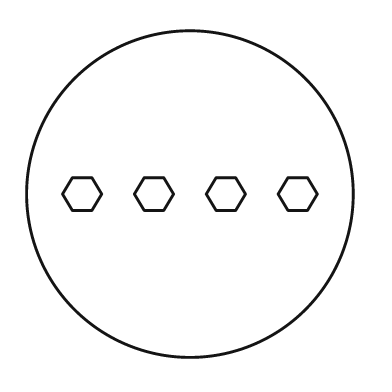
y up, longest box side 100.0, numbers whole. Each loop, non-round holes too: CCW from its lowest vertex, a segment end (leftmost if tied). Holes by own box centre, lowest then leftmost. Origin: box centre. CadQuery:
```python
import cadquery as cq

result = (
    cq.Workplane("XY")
    .moveTo(0.0, 0.0)
    .circle(50.0)
    .moveTo(-36.0, -5.0)
    .lineTo(-30.0, -5.0)
    .lineTo(-27.0, 0.0)
    .lineTo(-30.0, 5.0)
    .lineTo(-36.0, 5.0)
    .lineTo(-39.0, 0.0)
    .close()
    .moveTo(-14.0, -5.0)
    .lineTo(-8.0, -5.0)
    .lineTo(-5.0, 0.0)
    .lineTo(-8.0, 5.0)
    .lineTo(-14.0, 5.0)
    .lineTo(-17.0, 0.0)
    .close()
    .moveTo(8.0, -5.0)
    .lineTo(14.0, -5.0)
    .lineTo(17.0, 0.0)
    .lineTo(14.0, 5.0)
    .lineTo(8.0, 5.0)
    .lineTo(5.0, 0.0)
    .close()
    .moveTo(30.0, -5.0)
    .lineTo(36.0, -5.0)
    .lineTo(39.0, 0.0)
    .lineTo(36.0, 5.0)
    .lineTo(30.0, 5.0)
    .lineTo(27.0, 0.0)
    .close()
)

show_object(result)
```